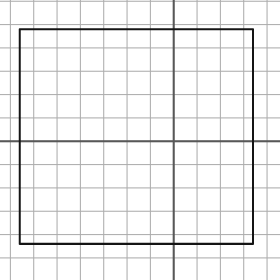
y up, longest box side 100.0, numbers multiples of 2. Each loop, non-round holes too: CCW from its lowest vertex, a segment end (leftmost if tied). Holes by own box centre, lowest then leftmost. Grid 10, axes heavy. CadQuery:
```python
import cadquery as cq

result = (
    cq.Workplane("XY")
    .moveTo(-66.0, -44.0)
    .lineTo(34.0, -44.0)
    .lineTo(34.0, 48.0)
    .lineTo(-66.0, 48.0)
    .close()
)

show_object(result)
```